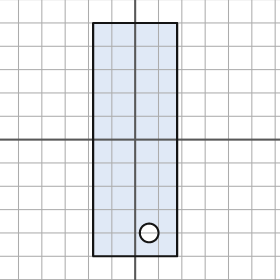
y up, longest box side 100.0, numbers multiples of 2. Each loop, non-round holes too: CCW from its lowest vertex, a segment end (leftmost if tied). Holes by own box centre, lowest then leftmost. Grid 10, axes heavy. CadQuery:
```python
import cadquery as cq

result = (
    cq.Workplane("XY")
    .moveTo(-18.0, -50.0)
    .lineTo(18.0, -50.0)
    .lineTo(18.0, 50.0)
    .lineTo(-18.0, 50.0)
    .close()
    .moveTo(6.0, -40.0)
    .circle(4.0)
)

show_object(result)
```